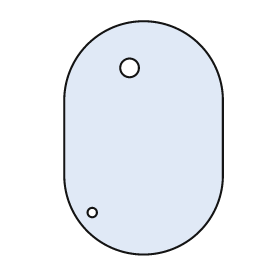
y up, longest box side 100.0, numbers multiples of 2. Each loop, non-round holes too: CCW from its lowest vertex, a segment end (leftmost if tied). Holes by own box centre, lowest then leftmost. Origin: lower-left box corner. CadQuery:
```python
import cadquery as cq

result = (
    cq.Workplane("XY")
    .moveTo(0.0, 34.0)
    .threePointArc((34.0, 0.0), (68.0, 34.0))
    .lineTo(68.0, 66.0)
    .threePointArc((34.0, 100.0), (0.0, 66.0))
    .close()
    .moveTo(12.0, 18.0)
    .circle(2.0)
    .moveTo(28.0, 80.0)
    .circle(4.0)
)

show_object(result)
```